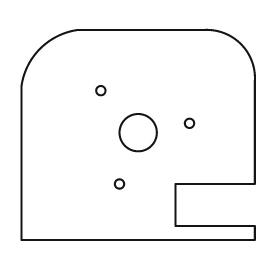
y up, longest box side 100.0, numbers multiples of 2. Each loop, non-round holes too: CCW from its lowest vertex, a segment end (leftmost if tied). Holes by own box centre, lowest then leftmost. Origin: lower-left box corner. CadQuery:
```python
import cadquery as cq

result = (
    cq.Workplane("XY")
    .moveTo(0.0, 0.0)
    .lineTo(100.0, 0.0)
    .lineTo(100.0, 6.0)
    .lineTo(66.0, 6.0)
    .lineTo(66.0, 24.0)
    .lineTo(100.0, 24.0)
    .lineTo(100.0, 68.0)
    .threePointArc((94.0, 84.0), (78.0, 90.0))
    .lineTo(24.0, 90.0)
    .threePointArc((8.0, 82.0), (0.0, 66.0))
    .close()
    .moveTo(42.0, 24.0)
    .circle(2.0)
    .moveTo(50.0, 46.0)
    .circle(8.0)
    .moveTo(72.0, 50.0)
    .circle(2.0)
    .moveTo(34.0, 64.0)
    .circle(2.0)
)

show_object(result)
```